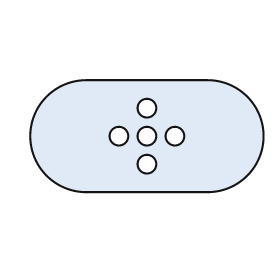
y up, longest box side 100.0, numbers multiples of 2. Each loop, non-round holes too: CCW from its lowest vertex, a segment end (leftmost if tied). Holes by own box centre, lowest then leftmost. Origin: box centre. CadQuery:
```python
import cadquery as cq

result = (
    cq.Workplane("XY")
    .moveTo(-26.0, -24.0)
    .lineTo(26.0, -24.0)
    .threePointArc((50.0, 0.0), (26.0, 24.0))
    .lineTo(-26.0, 24.0)
    .threePointArc((-50.0, 0.0), (-26.0, -24.0))
    .close()
    .moveTo(0.0, -12.0)
    .circle(4.0)
    .moveTo(-12.0, 0.0)
    .circle(4.0)
    .moveTo(0.0, 0.0)
    .circle(4.0)
    .moveTo(12.0, 0.0)
    .circle(4.0)
    .moveTo(0.0, 12.0)
    .circle(4.0)
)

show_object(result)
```